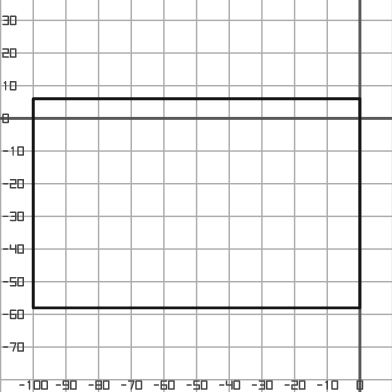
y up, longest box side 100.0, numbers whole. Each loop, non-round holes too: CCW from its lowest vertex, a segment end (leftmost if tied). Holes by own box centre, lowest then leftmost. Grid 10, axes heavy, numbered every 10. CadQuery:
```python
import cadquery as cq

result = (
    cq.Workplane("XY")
    .moveTo(-100.0, -58.0)
    .lineTo(0.0, -58.0)
    .lineTo(0.0, 6.0)
    .lineTo(-100.0, 6.0)
    .close()
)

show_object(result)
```